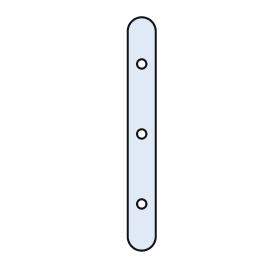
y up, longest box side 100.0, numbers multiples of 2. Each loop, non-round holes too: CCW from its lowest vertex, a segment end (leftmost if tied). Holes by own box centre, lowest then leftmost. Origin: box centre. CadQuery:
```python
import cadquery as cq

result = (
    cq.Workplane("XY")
    .moveTo(-6.0, -44.0)
    .threePointArc((0.0, -50.0), (6.0, -44.0))
    .lineTo(6.0, 44.0)
    .threePointArc((0.0, 50.0), (-6.0, 44.0))
    .close()
    .moveTo(0.0, -30.0)
    .circle(2.0)
    .moveTo(0.0, 0.0)
    .circle(2.0)
    .moveTo(0.0, 30.0)
    .circle(2.0)
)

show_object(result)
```